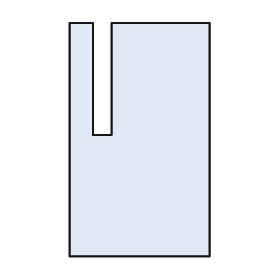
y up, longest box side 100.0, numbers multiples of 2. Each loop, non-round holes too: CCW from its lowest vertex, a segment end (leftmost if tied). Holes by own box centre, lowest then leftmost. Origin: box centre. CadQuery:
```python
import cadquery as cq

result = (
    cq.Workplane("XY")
    .moveTo(-30.0, -50.0)
    .lineTo(30.0, -50.0)
    .lineTo(30.0, 50.0)
    .lineTo(-12.0, 50.0)
    .lineTo(-12.0, 2.0)
    .lineTo(-20.0, 2.0)
    .lineTo(-20.0, 50.0)
    .lineTo(-30.0, 50.0)
    .close()
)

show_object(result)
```